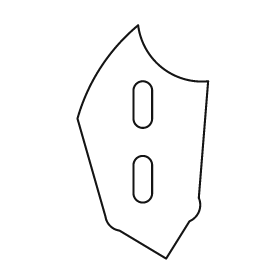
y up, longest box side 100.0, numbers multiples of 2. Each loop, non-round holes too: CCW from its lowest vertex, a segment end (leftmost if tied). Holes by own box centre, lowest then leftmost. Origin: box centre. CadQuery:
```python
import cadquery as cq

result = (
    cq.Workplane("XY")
    .moveTo(10.0, -50.0)
    .lineTo(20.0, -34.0)
    .threePointArc((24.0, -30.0), (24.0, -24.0))
    .lineTo(28.0, 26.0)
    .threePointArc((8.0, 32.0), (-2.0, 50.0))
    .threePointArc((-18.0, 32.0), (-28.0, 10.0))
    .lineTo(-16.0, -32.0)
    .threePointArc((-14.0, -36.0), (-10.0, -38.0))
    .close()
    .moveTo(-4.0, -22.0)
    .threePointArc((0.0, -26.0), (4.0, -22.0))
    .lineTo(4.0, -10.0)
    .threePointArc((0.0, -6.0), (-4.0, -10.0))
    .close()
    .moveTo(-4.0, 10.0)
    .threePointArc((0.0, 6.0), (4.0, 10.0))
    .lineTo(4.0, 22.0)
    .threePointArc((0.0, 26.0), (-4.0, 22.0))
    .close()
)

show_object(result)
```